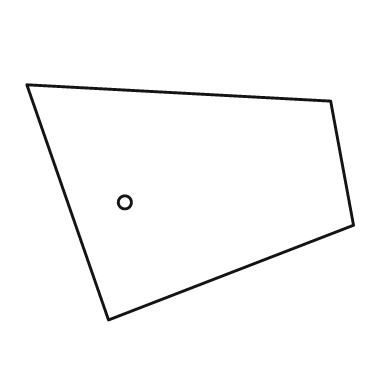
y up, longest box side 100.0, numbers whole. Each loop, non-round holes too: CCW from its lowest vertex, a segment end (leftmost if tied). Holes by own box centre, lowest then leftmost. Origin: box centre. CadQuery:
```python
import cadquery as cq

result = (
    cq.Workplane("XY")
    .moveTo(-25.0, -36.0)
    .lineTo(50.0, -7.0)
    .lineTo(43.0, 31.0)
    .lineTo(-50.0, 36.0)
    .close()
    .moveTo(-20.0, 0.0)
    .circle(2.0)
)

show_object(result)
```